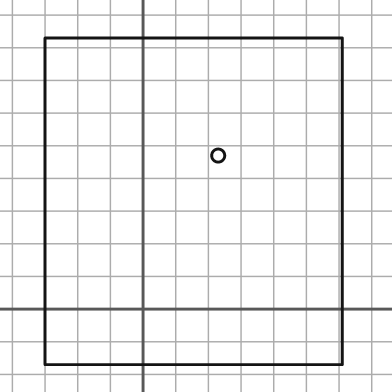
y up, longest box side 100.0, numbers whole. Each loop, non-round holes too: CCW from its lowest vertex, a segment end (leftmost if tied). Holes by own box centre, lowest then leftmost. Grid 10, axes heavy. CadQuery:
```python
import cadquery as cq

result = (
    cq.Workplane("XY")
    .moveTo(-30.0, -17.0)
    .lineTo(61.0, -17.0)
    .lineTo(61.0, 83.0)
    .lineTo(-30.0, 83.0)
    .close()
    .moveTo(23.0, 47.0)
    .circle(2.0)
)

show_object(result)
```